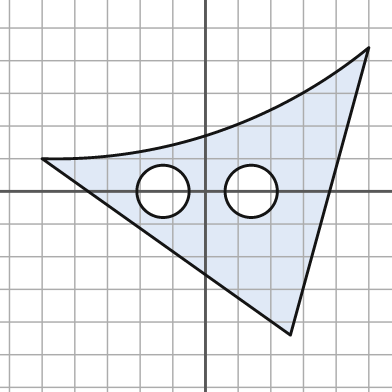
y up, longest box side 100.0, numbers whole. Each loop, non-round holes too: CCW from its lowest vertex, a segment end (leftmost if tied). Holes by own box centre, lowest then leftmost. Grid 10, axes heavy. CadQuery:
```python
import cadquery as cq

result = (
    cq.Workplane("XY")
    .moveTo(26.0, -44.0)
    .lineTo(50.0, 44.0)
    .threePointArc((3.0, 18.0), (-50.0, 10.0))
    .close()
    .moveTo(-13.0, 0.0)
    .circle(8.0)
    .moveTo(14.0, 0.0)
    .circle(8.0)
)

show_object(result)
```